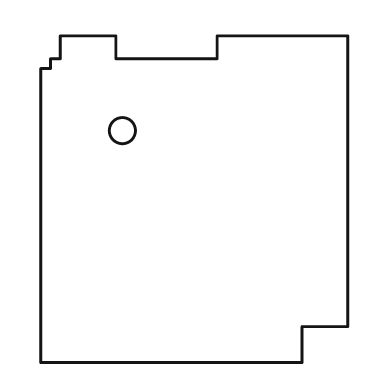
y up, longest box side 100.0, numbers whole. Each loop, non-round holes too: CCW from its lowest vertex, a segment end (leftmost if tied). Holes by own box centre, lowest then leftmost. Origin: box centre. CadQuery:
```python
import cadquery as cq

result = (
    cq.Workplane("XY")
    .moveTo(-47.0, -50.0)
    .lineTo(33.0, -50.0)
    .lineTo(33.0, -39.0)
    .lineTo(47.0, -39.0)
    .lineTo(47.0, 50.0)
    .lineTo(7.0, 50.0)
    .lineTo(7.0, 43.0)
    .lineTo(-24.0, 43.0)
    .lineTo(-24.0, 50.0)
    .lineTo(-41.0, 50.0)
    .lineTo(-41.0, 43.0)
    .lineTo(-44.0, 43.0)
    .lineTo(-44.0, 40.0)
    .lineTo(-47.0, 40.0)
    .close()
    .moveTo(-22.0, 21.0)
    .circle(4.0)
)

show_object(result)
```